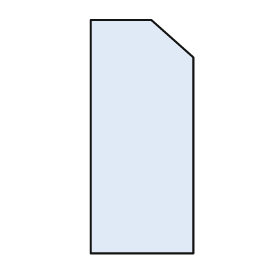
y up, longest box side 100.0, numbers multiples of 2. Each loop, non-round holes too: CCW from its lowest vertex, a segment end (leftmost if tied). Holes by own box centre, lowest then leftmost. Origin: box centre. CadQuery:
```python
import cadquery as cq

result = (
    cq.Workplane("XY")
    .moveTo(-22.0, -50.0)
    .lineTo(22.0, -50.0)
    .lineTo(22.0, 34.0)
    .lineTo(4.0, 50.0)
    .lineTo(-22.0, 50.0)
    .close()
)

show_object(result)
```